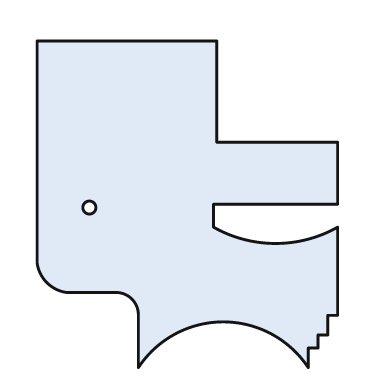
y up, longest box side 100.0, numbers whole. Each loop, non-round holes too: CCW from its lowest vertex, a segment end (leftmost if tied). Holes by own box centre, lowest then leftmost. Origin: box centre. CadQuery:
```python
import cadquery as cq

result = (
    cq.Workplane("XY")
    .moveTo(-15.0, -50.0)
    .threePointArc((11.0, -36.0), (37.0, -50.0))
    .lineTo(37.0, -44.0)
    .lineTo(40.0, -44.0)
    .lineTo(40.0, -40.0)
    .lineTo(43.0, -40.0)
    .lineTo(43.0, -34.0)
    .lineTo(46.0, -34.0)
    .lineTo(46.0, -7.0)
    .threePointArc((27.0, -12.0), (8.0, -7.0))
    .lineTo(8.0, 0.0)
    .lineTo(46.0, 0.0)
    .lineTo(46.0, 19.0)
    .lineTo(9.0, 19.0)
    .lineTo(9.0, 50.0)
    .lineTo(-46.0, 50.0)
    .lineTo(-46.0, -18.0)
    .threePointArc((-43.0, -24.0), (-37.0, -27.0))
    .lineTo(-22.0, -27.0)
    .threePointArc((-17.0, -29.0), (-15.0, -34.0))
    .close()
    .moveTo(-30.0, -1.0)
    .circle(2.0)
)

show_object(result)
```